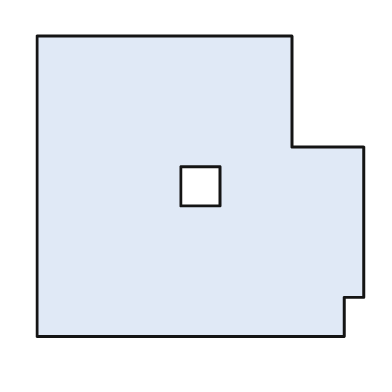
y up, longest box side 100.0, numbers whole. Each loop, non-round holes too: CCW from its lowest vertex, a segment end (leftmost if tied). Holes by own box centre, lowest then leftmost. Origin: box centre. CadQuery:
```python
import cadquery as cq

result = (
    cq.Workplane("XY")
    .moveTo(-50.0, -46.0)
    .lineTo(44.0, -46.0)
    .lineTo(44.0, -34.0)
    .lineTo(50.0, -34.0)
    .lineTo(50.0, 12.0)
    .lineTo(28.0, 12.0)
    .lineTo(28.0, 46.0)
    .lineTo(-50.0, 46.0)
    .close()
    .moveTo(-6.0, -6.0)
    .lineTo(6.0, -6.0)
    .lineTo(6.0, 6.0)
    .lineTo(-6.0, 6.0)
    .close()
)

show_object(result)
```